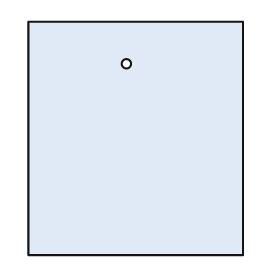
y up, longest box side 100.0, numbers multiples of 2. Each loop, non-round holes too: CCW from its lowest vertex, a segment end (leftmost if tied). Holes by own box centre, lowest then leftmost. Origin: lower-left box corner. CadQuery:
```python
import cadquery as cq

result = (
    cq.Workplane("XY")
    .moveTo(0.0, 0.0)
    .lineTo(92.0, 0.0)
    .lineTo(92.0, 100.0)
    .lineTo(0.0, 100.0)
    .close()
    .moveTo(42.0, 82.0)
    .circle(2.0)
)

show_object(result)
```